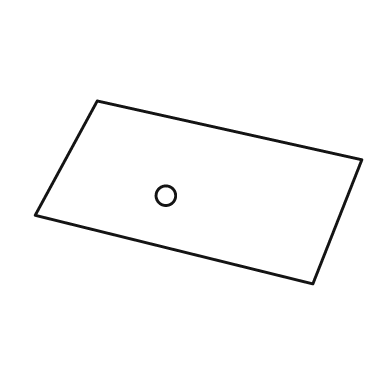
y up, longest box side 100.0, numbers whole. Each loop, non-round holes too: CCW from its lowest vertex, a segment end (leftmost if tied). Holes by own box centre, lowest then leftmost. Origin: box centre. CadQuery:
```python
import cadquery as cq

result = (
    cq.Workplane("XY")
    .moveTo(35.0, -28.0)
    .lineTo(50.0, 10.0)
    .lineTo(-31.0, 28.0)
    .lineTo(-50.0, -7.0)
    .close()
    .moveTo(-10.0, -1.0)
    .circle(3.0)
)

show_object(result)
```